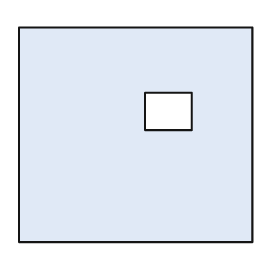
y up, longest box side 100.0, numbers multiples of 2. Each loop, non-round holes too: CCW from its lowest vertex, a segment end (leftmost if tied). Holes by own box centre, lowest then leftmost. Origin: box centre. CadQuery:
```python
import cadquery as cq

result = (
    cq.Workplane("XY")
    .moveTo(-50.0, -46.0)
    .lineTo(50.0, -46.0)
    .lineTo(50.0, 46.0)
    .lineTo(-50.0, 46.0)
    .close()
    .moveTo(4.0, 2.0)
    .lineTo(24.0, 2.0)
    .lineTo(24.0, 18.0)
    .lineTo(4.0, 18.0)
    .close()
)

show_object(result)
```